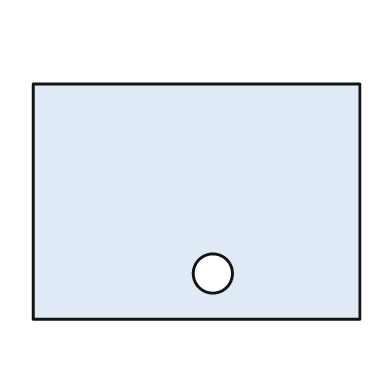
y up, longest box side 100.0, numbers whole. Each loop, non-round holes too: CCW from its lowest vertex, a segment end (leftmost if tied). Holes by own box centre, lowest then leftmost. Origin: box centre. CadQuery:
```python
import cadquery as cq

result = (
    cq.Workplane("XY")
    .moveTo(-50.0, -36.0)
    .lineTo(50.0, -36.0)
    .lineTo(50.0, 36.0)
    .lineTo(-50.0, 36.0)
    .close()
    .moveTo(5.0, -22.0)
    .circle(6.0)
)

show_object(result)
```